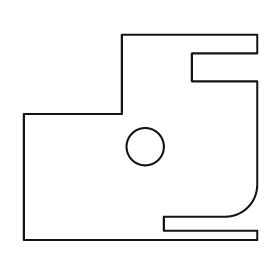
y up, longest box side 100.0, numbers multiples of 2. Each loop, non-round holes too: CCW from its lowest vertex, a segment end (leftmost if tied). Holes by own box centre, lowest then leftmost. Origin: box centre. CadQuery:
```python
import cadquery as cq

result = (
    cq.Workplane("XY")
    .moveTo(-50.0, -44.0)
    .lineTo(50.0, -44.0)
    .lineTo(50.0, -40.0)
    .lineTo(10.0, -40.0)
    .lineTo(10.0, -34.0)
    .lineTo(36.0, -34.0)
    .threePointArc((46.0, -30.0), (50.0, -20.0))
    .lineTo(50.0, 24.0)
    .lineTo(22.0, 24.0)
    .lineTo(22.0, 36.0)
    .lineTo(50.0, 36.0)
    .lineTo(50.0, 44.0)
    .lineTo(-8.0, 44.0)
    .lineTo(-8.0, 10.0)
    .lineTo(-50.0, 10.0)
    .close()
    .moveTo(2.0, -4.0)
    .circle(8.0)
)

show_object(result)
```